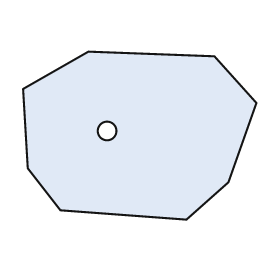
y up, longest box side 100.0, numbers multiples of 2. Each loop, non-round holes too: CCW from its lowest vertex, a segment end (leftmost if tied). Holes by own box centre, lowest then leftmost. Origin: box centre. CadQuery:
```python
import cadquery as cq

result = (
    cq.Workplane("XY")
    .moveTo(20.0, -36.0)
    .lineTo(38.0, -20.0)
    .lineTo(50.0, 14.0)
    .lineTo(32.0, 34.0)
    .lineTo(-22.0, 36.0)
    .lineTo(-50.0, 20.0)
    .lineTo(-48.0, -14.0)
    .lineTo(-34.0, -32.0)
    .close()
    .moveTo(-14.0, 2.0)
    .circle(4.0)
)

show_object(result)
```